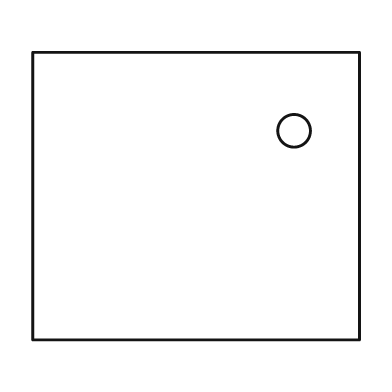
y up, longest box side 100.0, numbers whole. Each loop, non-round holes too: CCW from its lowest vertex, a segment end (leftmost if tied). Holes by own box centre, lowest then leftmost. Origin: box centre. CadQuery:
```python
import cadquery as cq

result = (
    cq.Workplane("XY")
    .moveTo(-50.0, -44.0)
    .lineTo(50.0, -44.0)
    .lineTo(50.0, 44.0)
    .lineTo(-50.0, 44.0)
    .close()
    .moveTo(30.0, 20.0)
    .circle(5.0)
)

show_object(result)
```